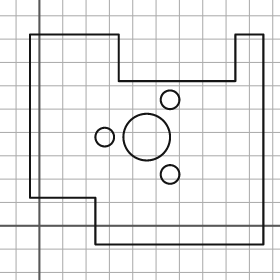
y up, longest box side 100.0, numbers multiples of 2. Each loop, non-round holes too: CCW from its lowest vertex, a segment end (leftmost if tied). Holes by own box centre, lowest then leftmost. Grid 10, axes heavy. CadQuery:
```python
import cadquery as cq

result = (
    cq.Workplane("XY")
    .moveTo(24.0, -8.0)
    .lineTo(96.0, -8.0)
    .lineTo(96.0, 82.0)
    .lineTo(84.0, 82.0)
    .lineTo(84.0, 62.0)
    .lineTo(34.0, 62.0)
    .lineTo(34.0, 82.0)
    .lineTo(-4.0, 82.0)
    .lineTo(-4.0, 12.0)
    .lineTo(24.0, 12.0)
    .close()
    .moveTo(56.0, 22.0)
    .circle(4.0)
    .moveTo(28.0, 38.0)
    .circle(4.0)
    .moveTo(46.0, 38.0)
    .circle(10.0)
    .moveTo(56.0, 54.0)
    .circle(4.0)
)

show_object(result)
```